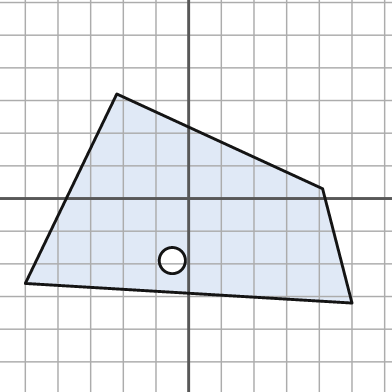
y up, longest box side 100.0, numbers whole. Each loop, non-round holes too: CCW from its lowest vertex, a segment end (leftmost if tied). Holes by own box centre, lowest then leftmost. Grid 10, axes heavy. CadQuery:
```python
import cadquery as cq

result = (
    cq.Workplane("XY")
    .moveTo(50.0, -32.0)
    .lineTo(41.0, 3.0)
    .lineTo(-22.0, 32.0)
    .lineTo(-50.0, -26.0)
    .close()
    .moveTo(-5.0, -19.0)
    .circle(4.0)
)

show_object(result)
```